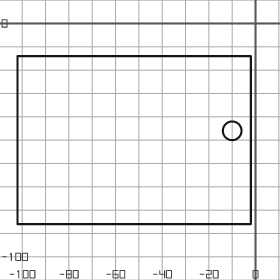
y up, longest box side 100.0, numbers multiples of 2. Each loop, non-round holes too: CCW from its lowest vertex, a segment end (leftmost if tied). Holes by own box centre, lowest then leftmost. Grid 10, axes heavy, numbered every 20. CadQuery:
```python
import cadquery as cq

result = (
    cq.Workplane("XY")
    .moveTo(-102.0, -86.0)
    .lineTo(-2.0, -86.0)
    .lineTo(-2.0, -14.0)
    .lineTo(-102.0, -14.0)
    .close()
    .moveTo(-10.0, -46.0)
    .circle(4.0)
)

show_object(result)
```